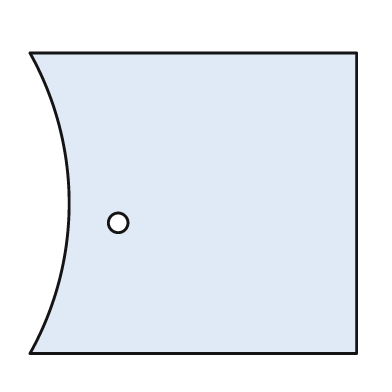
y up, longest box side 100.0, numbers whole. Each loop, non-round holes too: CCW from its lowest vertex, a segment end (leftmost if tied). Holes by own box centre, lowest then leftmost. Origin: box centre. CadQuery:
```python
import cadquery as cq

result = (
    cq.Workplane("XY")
    .moveTo(-50.0, -46.0)
    .lineTo(50.0, -46.0)
    .lineTo(50.0, 46.0)
    .lineTo(-50.0, 46.0)
    .threePointArc((-38.0, 0.0), (-50.0, -46.0))
    .close()
    .moveTo(-23.0, -6.0)
    .circle(3.0)
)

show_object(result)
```